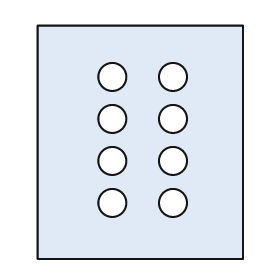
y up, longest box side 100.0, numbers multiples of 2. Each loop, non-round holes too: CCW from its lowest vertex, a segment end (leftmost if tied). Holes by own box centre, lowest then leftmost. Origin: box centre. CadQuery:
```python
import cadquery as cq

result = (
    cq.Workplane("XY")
    .moveTo(-44.0, -50.0)
    .lineTo(44.0, -50.0)
    .lineTo(44.0, 50.0)
    .lineTo(-44.0, 50.0)
    .close()
    .moveTo(-12.0, -26.0)
    .circle(6.0)
    .moveTo(14.0, -26.0)
    .circle(6.0)
    .moveTo(-12.0, -8.0)
    .circle(6.0)
    .moveTo(14.0, -8.0)
    .circle(6.0)
    .moveTo(-12.0, 10.0)
    .circle(6.0)
    .moveTo(14.0, 10.0)
    .circle(6.0)
    .moveTo(-12.0, 28.0)
    .circle(6.0)
    .moveTo(14.0, 28.0)
    .circle(6.0)
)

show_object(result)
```